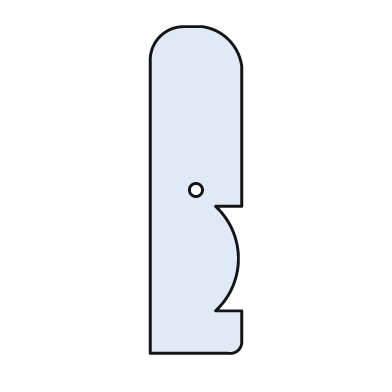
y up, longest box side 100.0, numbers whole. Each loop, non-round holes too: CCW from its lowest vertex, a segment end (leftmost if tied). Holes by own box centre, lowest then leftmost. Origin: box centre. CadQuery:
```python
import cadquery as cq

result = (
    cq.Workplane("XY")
    .moveTo(-14.0, -50.0)
    .lineTo(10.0, -50.0)
    .threePointArc((13.0, -49.0), (14.0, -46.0))
    .lineTo(14.0, -37.0)
    .lineTo(6.0, -37.0)
    .threePointArc((13.0, -21.0), (6.0, -5.0))
    .lineTo(14.0, -5.0)
    .lineTo(14.0, 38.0)
    .threePointArc((10.0, 46.0), (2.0, 50.0))
    .lineTo(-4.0, 50.0)
    .threePointArc((-11.0, 47.0), (-14.0, 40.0))
    .close()
    .moveTo(0.0, 0.0)
    .circle(2.0)
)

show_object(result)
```